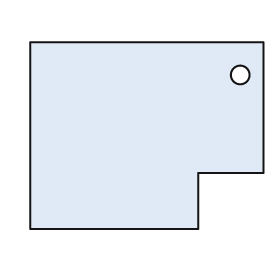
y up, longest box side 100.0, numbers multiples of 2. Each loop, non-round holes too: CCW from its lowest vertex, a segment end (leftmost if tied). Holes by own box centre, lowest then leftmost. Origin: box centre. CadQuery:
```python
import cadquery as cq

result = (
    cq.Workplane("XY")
    .moveTo(-50.0, -40.0)
    .lineTo(22.0, -40.0)
    .lineTo(22.0, -16.0)
    .lineTo(50.0, -16.0)
    .lineTo(50.0, 40.0)
    .lineTo(-50.0, 40.0)
    .close()
    .moveTo(40.0, 26.0)
    .circle(4.0)
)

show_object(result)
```